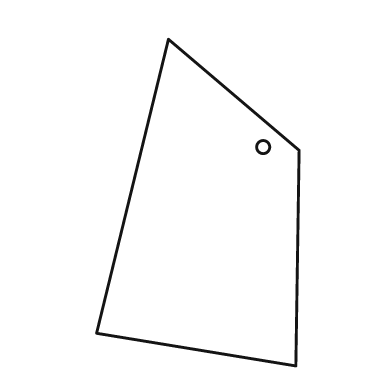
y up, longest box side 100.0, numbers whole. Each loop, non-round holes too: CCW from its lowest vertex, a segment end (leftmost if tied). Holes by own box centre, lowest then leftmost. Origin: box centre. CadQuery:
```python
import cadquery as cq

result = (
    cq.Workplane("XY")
    .moveTo(30.0, -50.0)
    .lineTo(31.0, 16.0)
    .lineTo(-9.0, 50.0)
    .lineTo(-31.0, -40.0)
    .close()
    .moveTo(20.0, 17.0)
    .circle(2.0)
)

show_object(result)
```